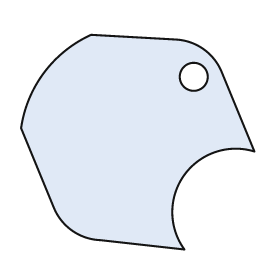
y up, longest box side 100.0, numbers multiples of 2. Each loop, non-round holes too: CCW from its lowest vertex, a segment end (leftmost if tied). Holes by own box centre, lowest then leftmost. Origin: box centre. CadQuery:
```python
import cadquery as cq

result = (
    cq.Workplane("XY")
    .moveTo(20.0, -46.0)
    .threePointArc((20.0, -14.0), (50.0, -4.0))
    .lineTo(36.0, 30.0)
    .threePointArc((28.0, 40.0), (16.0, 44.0))
    .lineTo(-20.0, 46.0)
    .threePointArc((-40.0, 30.0), (-50.0, 6.0))
    .lineTo(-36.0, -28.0)
    .threePointArc((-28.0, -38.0), (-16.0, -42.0))
    .close()
    .moveTo(24.0, 28.0)
    .circle(6.0)
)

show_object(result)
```